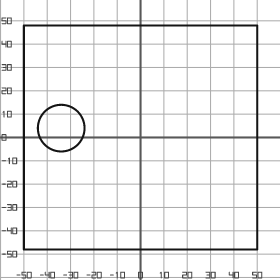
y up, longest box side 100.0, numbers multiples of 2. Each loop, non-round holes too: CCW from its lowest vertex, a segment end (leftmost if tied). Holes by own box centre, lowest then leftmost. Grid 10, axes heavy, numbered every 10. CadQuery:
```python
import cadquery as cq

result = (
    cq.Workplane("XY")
    .moveTo(-50.0, -48.0)
    .lineTo(50.0, -48.0)
    .lineTo(50.0, 48.0)
    .lineTo(-50.0, 48.0)
    .close()
    .moveTo(-34.0, 4.0)
    .circle(10.0)
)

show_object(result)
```